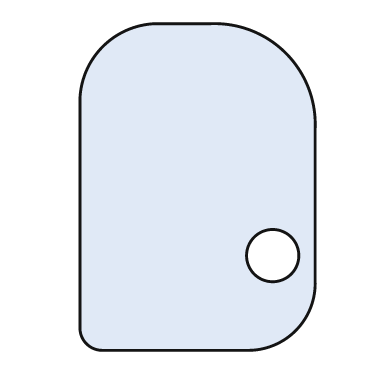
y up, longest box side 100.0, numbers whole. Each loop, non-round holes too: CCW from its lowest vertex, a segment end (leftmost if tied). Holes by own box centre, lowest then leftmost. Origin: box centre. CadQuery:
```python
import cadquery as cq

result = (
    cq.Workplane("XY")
    .moveTo(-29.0, -50.0)
    .lineTo(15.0, -50.0)
    .threePointArc((30.0, -44.0), (36.0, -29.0))
    .lineTo(36.0, 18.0)
    .threePointArc((27.0, 41.0), (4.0, 50.0))
    .lineTo(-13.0, 50.0)
    .threePointArc((-29.0, 43.0), (-36.0, 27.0))
    .lineTo(-36.0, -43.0)
    .threePointArc((-34.0, -48.0), (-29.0, -50.0))
    .close()
    .moveTo(23.0, -21.0)
    .circle(8.0)
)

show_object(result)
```